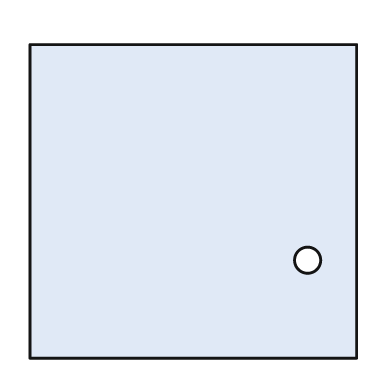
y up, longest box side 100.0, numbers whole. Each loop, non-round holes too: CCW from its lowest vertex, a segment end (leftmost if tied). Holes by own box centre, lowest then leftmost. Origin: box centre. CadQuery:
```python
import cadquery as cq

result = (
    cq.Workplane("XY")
    .moveTo(-50.0, -48.0)
    .lineTo(50.0, -48.0)
    .lineTo(50.0, 48.0)
    .lineTo(-50.0, 48.0)
    .close()
    .moveTo(35.0, -18.0)
    .circle(4.0)
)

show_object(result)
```